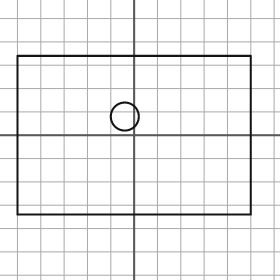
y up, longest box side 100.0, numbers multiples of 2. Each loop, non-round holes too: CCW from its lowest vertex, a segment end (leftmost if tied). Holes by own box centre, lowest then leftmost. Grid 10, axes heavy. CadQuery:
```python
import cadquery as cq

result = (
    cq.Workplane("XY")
    .moveTo(-50.0, -34.0)
    .lineTo(50.0, -34.0)
    .lineTo(50.0, 34.0)
    .lineTo(-50.0, 34.0)
    .close()
    .moveTo(-4.0, 8.0)
    .circle(6.0)
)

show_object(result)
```